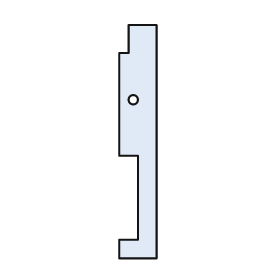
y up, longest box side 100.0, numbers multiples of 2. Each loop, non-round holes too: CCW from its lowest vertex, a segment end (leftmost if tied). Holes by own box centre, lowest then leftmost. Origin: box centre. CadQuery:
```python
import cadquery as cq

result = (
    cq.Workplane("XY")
    .moveTo(-8.0, -50.0)
    .lineTo(8.0, -50.0)
    .lineTo(8.0, 50.0)
    .lineTo(-4.0, 50.0)
    .lineTo(-4.0, 38.0)
    .lineTo(-8.0, 38.0)
    .lineTo(-8.0, -6.0)
    .lineTo(0.0, -6.0)
    .lineTo(0.0, -42.0)
    .lineTo(-8.0, -42.0)
    .close()
    .moveTo(-2.0, 18.0)
    .circle(2.0)
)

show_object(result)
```